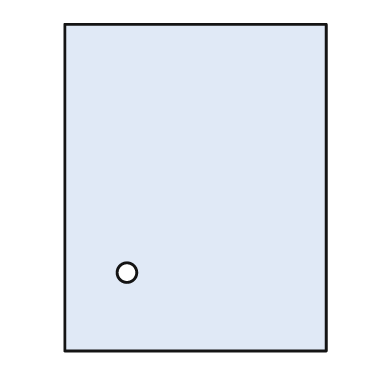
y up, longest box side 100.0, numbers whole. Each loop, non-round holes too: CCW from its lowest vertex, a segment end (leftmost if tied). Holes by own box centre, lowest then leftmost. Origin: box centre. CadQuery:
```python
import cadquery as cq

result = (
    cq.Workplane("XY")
    .moveTo(-40.0, -50.0)
    .lineTo(40.0, -50.0)
    .lineTo(40.0, 50.0)
    .lineTo(-40.0, 50.0)
    .close()
    .moveTo(-21.0, -26.0)
    .circle(3.0)
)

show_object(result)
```